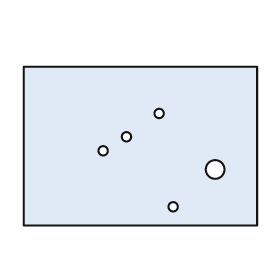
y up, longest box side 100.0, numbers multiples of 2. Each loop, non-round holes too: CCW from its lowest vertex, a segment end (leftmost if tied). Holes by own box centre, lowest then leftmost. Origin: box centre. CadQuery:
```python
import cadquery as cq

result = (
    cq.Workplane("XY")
    .moveTo(-50.0, -34.0)
    .lineTo(50.0, -34.0)
    .lineTo(50.0, 34.0)
    .lineTo(-50.0, 34.0)
    .close()
    .moveTo(14.0, -26.0)
    .circle(2.0)
    .moveTo(32.0, -10.0)
    .circle(4.0)
    .moveTo(-16.0, -2.0)
    .circle(2.0)
    .moveTo(-6.0, 4.0)
    .circle(2.0)
    .moveTo(8.0, 14.0)
    .circle(2.0)
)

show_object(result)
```